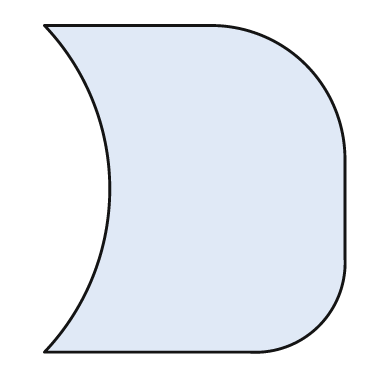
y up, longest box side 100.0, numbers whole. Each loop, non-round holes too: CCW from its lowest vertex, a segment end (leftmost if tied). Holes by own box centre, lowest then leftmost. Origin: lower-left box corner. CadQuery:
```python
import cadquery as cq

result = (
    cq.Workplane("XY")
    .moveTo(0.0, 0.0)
    .lineTo(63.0, 0.0)
    .threePointArc((84.0, 8.0), (92.0, 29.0))
    .lineTo(92.0, 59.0)
    .threePointArc((80.0, 88.0), (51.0, 100.0))
    .lineTo(0.0, 100.0)
    .threePointArc((20.0, 50.0), (0.0, 0.0))
    .close()
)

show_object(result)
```